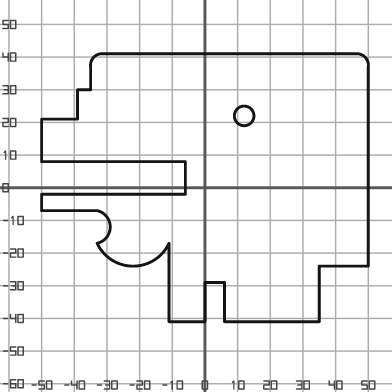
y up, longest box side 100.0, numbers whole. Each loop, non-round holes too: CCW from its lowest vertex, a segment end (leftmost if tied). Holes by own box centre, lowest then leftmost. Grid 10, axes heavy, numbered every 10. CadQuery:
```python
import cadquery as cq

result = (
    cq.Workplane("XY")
    .moveTo(-11.0, -41.0)
    .lineTo(0.0, -41.0)
    .lineTo(0.0, -29.0)
    .lineTo(6.0, -29.0)
    .lineTo(6.0, -41.0)
    .lineTo(35.0, -41.0)
    .lineTo(35.0, -24.0)
    .lineTo(50.0, -24.0)
    .lineTo(50.0, 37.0)
    .threePointArc((49.0, 40.0), (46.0, 41.0))
    .lineTo(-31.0, 41.0)
    .threePointArc((-34.0, 40.0), (-35.0, 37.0))
    .lineTo(-35.0, 30.0)
    .lineTo(-39.0, 30.0)
    .lineTo(-39.0, 21.0)
    .lineTo(-50.0, 21.0)
    .lineTo(-50.0, 8.0)
    .lineTo(-6.0, 8.0)
    .lineTo(-6.0, -2.0)
    .lineTo(-50.0, -2.0)
    .lineTo(-50.0, -7.0)
    .lineTo(-33.0, -7.0)
    .threePointArc((-29.0, -12.0), (-33.0, -17.0))
    .threePointArc((-22.0, -24.0), (-11.0, -17.0))
    .close()
    .moveTo(12.0, 22.0)
    .circle(3.0)
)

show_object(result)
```